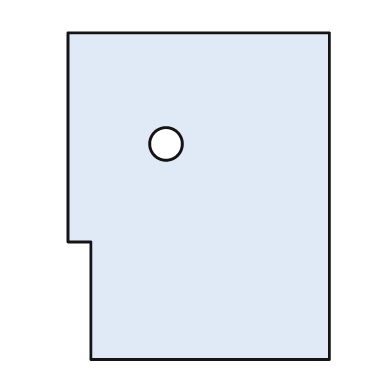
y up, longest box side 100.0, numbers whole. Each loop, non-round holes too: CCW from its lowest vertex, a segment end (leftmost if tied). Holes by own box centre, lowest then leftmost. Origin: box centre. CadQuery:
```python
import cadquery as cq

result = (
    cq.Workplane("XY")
    .moveTo(-33.0, -50.0)
    .lineTo(40.0, -50.0)
    .lineTo(40.0, 50.0)
    .lineTo(-40.0, 50.0)
    .lineTo(-40.0, -14.0)
    .lineTo(-33.0, -14.0)
    .close()
    .moveTo(-10.0, 16.0)
    .circle(5.0)
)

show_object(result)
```